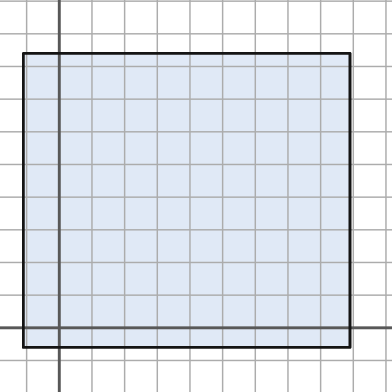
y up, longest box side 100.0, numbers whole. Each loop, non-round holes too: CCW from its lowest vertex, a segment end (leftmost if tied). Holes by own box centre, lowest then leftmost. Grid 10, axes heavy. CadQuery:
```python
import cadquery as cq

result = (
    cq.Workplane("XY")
    .moveTo(-11.0, -6.0)
    .lineTo(89.0, -6.0)
    .lineTo(89.0, 84.0)
    .lineTo(-11.0, 84.0)
    .close()
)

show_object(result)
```